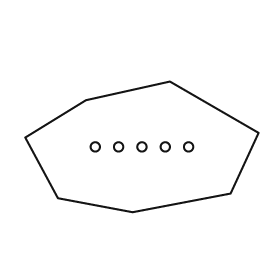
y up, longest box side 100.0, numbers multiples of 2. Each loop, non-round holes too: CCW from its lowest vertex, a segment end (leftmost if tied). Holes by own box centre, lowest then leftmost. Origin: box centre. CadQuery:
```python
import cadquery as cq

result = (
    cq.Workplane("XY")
    .moveTo(-4.0, -28.0)
    .lineTo(38.0, -20.0)
    .lineTo(50.0, 6.0)
    .lineTo(12.0, 28.0)
    .lineTo(-24.0, 20.0)
    .lineTo(-50.0, 4.0)
    .lineTo(-36.0, -22.0)
    .close()
    .moveTo(-20.0, 0.0)
    .circle(2.0)
    .moveTo(-10.0, 0.0)
    .circle(2.0)
    .moveTo(0.0, 0.0)
    .circle(2.0)
    .moveTo(10.0, 0.0)
    .circle(2.0)
    .moveTo(20.0, 0.0)
    .circle(2.0)
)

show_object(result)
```